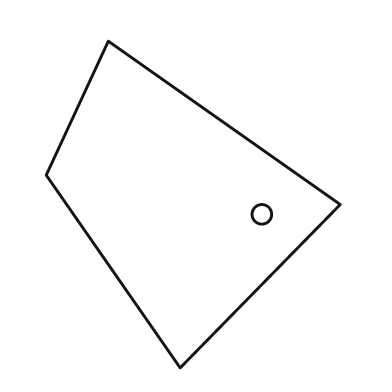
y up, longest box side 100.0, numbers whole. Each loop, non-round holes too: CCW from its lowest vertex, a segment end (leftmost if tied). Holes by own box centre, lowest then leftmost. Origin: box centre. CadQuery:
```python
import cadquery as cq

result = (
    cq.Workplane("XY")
    .moveTo(-4.0, -50.0)
    .lineTo(45.0, 0.0)
    .lineTo(-26.0, 50.0)
    .lineTo(-45.0, 9.0)
    .close()
    .moveTo(21.0, -3.0)
    .circle(3.0)
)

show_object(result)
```